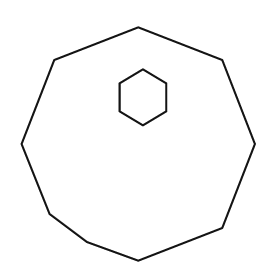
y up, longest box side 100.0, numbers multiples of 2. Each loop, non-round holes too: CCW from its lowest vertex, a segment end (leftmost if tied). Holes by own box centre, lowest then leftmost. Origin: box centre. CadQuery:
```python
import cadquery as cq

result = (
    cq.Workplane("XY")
    .moveTo(0.0, -50.0)
    .lineTo(36.0, -36.0)
    .lineTo(50.0, 0.0)
    .lineTo(36.0, 36.0)
    .lineTo(0.0, 50.0)
    .lineTo(-36.0, 36.0)
    .lineTo(-50.0, 0.0)
    .lineTo(-38.0, -30.0)
    .lineTo(-22.0, -42.0)
    .close()
    .moveTo(2.0, 8.0)
    .lineTo(12.0, 14.0)
    .lineTo(12.0, 26.0)
    .lineTo(2.0, 32.0)
    .lineTo(-8.0, 26.0)
    .lineTo(-8.0, 14.0)
    .close()
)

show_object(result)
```